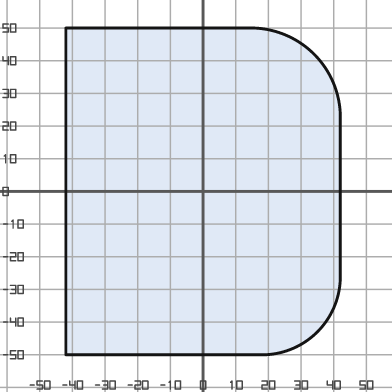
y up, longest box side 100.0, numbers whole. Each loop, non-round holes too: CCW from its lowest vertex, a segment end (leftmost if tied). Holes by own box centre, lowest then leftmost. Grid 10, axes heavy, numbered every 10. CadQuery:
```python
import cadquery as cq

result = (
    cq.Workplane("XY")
    .moveTo(-42.0, -50.0)
    .lineTo(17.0, -50.0)
    .threePointArc((35.0, -43.0), (42.0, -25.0))
    .lineTo(42.0, 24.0)
    .threePointArc((34.0, 42.0), (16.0, 50.0))
    .lineTo(-42.0, 50.0)
    .close()
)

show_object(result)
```